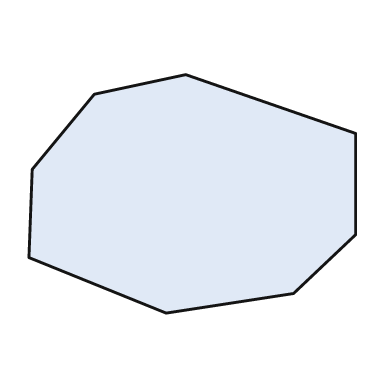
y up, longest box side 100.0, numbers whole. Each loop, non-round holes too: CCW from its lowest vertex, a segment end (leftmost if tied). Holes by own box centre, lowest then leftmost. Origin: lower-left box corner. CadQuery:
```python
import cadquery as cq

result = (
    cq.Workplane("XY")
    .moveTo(42.0, 0.0)
    .lineTo(81.0, 6.0)
    .lineTo(100.0, 24.0)
    .lineTo(100.0, 55.0)
    .lineTo(48.0, 73.0)
    .lineTo(20.0, 67.0)
    .lineTo(1.0, 44.0)
    .lineTo(0.0, 17.0)
    .close()
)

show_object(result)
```